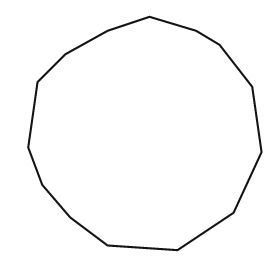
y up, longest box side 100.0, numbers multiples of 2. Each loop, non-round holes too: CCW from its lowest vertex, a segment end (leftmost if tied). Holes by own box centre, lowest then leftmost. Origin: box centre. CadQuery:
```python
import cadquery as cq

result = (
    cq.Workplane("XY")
    .moveTo(14.0, -50.0)
    .lineTo(38.0, -34.0)
    .lineTo(50.0, -8.0)
    .lineTo(46.0, 20.0)
    .lineTo(32.0, 38.0)
    .lineTo(22.0, 44.0)
    .lineTo(2.0, 50.0)
    .lineTo(-16.0, 44.0)
    .lineTo(-34.0, 34.0)
    .lineTo(-46.0, 22.0)
    .lineTo(-50.0, -6.0)
    .lineTo(-44.0, -22.0)
    .lineTo(-32.0, -36.0)
    .lineTo(-16.0, -48.0)
    .close()
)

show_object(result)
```